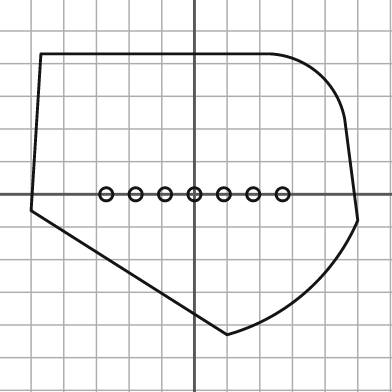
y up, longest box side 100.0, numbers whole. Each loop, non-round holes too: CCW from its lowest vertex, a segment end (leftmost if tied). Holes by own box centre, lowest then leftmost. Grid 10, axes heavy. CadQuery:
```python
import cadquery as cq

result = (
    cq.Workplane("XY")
    .moveTo(10.0, -43.0)
    .threePointArc((34.0, -30.0), (50.0, -8.0))
    .lineTo(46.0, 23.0)
    .threePointArc((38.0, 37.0), (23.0, 43.0))
    .lineTo(-47.0, 43.0)
    .lineTo(-50.0, -5.0)
    .close()
    .moveTo(-27.0, 0.0)
    .circle(2.0)
    .moveTo(-18.0, 0.0)
    .circle(2.0)
    .moveTo(-9.0, 0.0)
    .circle(2.0)
    .moveTo(0.0, 0.0)
    .circle(2.0)
    .moveTo(9.0, 0.0)
    .circle(2.0)
    .moveTo(18.0, 0.0)
    .circle(2.0)
    .moveTo(27.0, 0.0)
    .circle(2.0)
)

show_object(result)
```